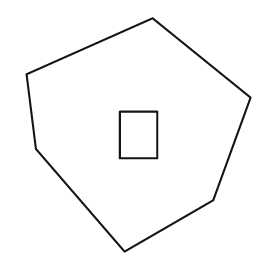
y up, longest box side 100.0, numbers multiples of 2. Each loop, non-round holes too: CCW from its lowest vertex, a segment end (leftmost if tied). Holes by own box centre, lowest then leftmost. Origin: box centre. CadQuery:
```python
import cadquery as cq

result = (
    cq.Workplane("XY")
    .moveTo(-6.0, -50.0)
    .lineTo(32.0, -28.0)
    .lineTo(48.0, 16.0)
    .lineTo(6.0, 50.0)
    .lineTo(-48.0, 26.0)
    .lineTo(-44.0, -6.0)
    .close()
    .moveTo(-8.0, -10.0)
    .lineTo(8.0, -10.0)
    .lineTo(8.0, 10.0)
    .lineTo(-8.0, 10.0)
    .close()
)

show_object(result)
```